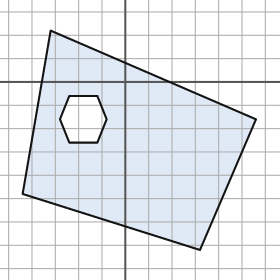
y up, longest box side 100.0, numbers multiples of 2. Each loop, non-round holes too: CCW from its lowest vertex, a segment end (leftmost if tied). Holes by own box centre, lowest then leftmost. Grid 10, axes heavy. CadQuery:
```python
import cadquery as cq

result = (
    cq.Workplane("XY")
    .moveTo(32.0, -72.0)
    .lineTo(56.0, -16.0)
    .lineTo(-32.0, 22.0)
    .lineTo(-44.0, -48.0)
    .close()
    .moveTo(-24.0, -26.0)
    .lineTo(-12.0, -26.0)
    .lineTo(-8.0, -16.0)
    .lineTo(-12.0, -6.0)
    .lineTo(-24.0, -6.0)
    .lineTo(-28.0, -16.0)
    .close()
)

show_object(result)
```